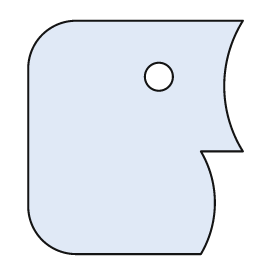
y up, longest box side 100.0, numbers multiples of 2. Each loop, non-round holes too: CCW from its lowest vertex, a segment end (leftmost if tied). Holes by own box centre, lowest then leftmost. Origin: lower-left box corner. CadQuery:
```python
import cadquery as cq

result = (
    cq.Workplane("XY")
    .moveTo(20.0, 0.0)
    .lineTo(74.0, 0.0)
    .threePointArc((80.0, 22.0), (74.0, 44.0))
    .lineTo(92.0, 44.0)
    .threePointArc((84.0, 72.0), (92.0, 100.0))
    .lineTo(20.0, 100.0)
    .threePointArc((6.0, 94.0), (0.0, 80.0))
    .lineTo(0.0, 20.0)
    .threePointArc((6.0, 6.0), (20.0, 0.0))
    .close()
    .moveTo(56.0, 76.0)
    .circle(6.0)
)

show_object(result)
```